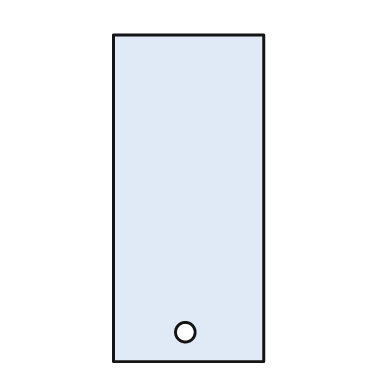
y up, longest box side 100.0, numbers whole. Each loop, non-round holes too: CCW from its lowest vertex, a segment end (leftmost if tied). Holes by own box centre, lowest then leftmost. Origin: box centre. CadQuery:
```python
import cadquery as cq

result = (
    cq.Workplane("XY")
    .moveTo(-23.0, -50.0)
    .lineTo(23.0, -50.0)
    .lineTo(23.0, 50.0)
    .lineTo(-23.0, 50.0)
    .close()
    .moveTo(-1.0, -41.0)
    .circle(3.0)
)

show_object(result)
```